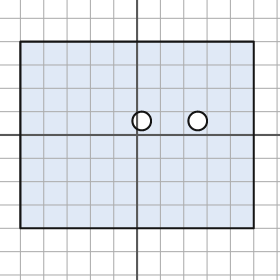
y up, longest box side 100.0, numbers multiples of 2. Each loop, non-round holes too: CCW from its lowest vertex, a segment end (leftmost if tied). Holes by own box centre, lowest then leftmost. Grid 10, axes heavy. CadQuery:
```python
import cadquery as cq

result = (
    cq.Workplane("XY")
    .moveTo(-50.0, -40.0)
    .lineTo(50.0, -40.0)
    .lineTo(50.0, 40.0)
    .lineTo(-50.0, 40.0)
    .close()
    .moveTo(2.0, 6.0)
    .circle(4.0)
    .moveTo(26.0, 6.0)
    .circle(4.0)
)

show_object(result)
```